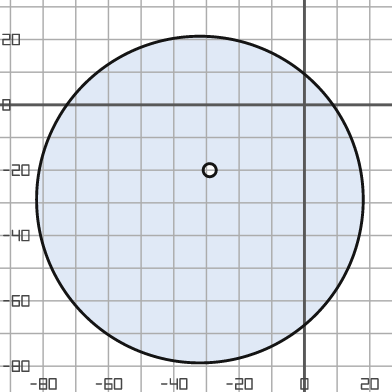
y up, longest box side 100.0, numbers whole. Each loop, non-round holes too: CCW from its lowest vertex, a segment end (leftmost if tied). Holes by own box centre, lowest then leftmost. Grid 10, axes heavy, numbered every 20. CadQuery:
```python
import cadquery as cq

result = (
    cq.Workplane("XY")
    .moveTo(-32.0, -29.0)
    .circle(50.0)
    .moveTo(-29.0, -20.0)
    .circle(2.0)
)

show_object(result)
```